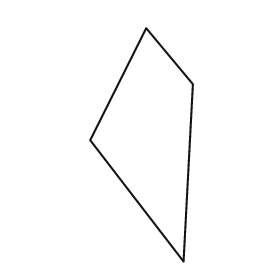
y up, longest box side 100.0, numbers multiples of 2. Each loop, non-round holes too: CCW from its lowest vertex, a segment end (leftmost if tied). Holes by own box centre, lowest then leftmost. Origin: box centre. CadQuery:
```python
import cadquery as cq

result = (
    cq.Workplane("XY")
    .moveTo(18.0, -50.0)
    .lineTo(22.0, 26.0)
    .lineTo(2.0, 50.0)
    .lineTo(-22.0, 2.0)
    .close()
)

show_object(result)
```